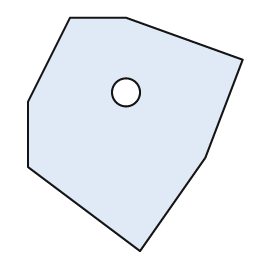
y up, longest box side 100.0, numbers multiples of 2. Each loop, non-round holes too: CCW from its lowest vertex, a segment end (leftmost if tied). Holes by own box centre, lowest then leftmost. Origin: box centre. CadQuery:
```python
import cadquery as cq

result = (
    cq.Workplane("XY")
    .moveTo(2.0, -50.0)
    .lineTo(30.0, -10.0)
    .lineTo(46.0, 32.0)
    .lineTo(-4.0, 50.0)
    .lineTo(-28.0, 50.0)
    .lineTo(-46.0, 14.0)
    .lineTo(-46.0, -14.0)
    .close()
    .moveTo(-4.0, 18.0)
    .circle(6.0)
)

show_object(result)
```